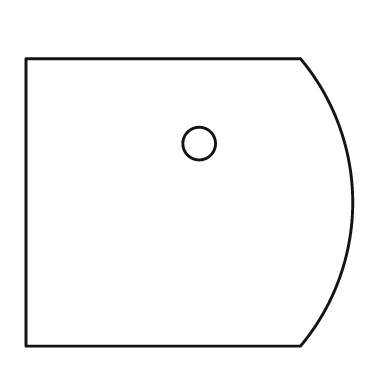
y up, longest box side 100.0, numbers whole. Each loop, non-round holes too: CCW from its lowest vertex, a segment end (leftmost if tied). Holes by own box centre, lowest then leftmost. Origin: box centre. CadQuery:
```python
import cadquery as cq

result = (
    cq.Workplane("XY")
    .moveTo(-50.0, -44.0)
    .lineTo(34.0, -44.0)
    .threePointArc((50.0, 0.0), (34.0, 44.0))
    .lineTo(-50.0, 44.0)
    .close()
    .moveTo(3.0, 18.0)
    .circle(5.0)
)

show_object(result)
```